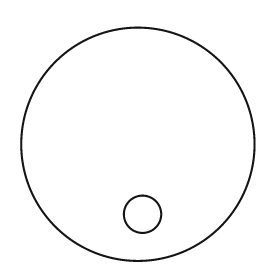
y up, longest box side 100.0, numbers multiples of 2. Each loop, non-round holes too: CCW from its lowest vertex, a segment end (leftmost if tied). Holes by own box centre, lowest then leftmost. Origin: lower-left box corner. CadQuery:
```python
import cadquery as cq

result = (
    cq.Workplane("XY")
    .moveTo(50.0, 50.0)
    .circle(50.0)
    .moveTo(52.0, 20.0)
    .circle(8.0)
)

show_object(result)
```